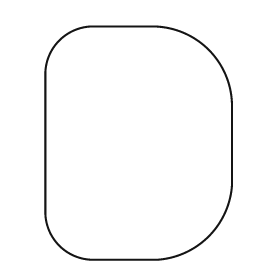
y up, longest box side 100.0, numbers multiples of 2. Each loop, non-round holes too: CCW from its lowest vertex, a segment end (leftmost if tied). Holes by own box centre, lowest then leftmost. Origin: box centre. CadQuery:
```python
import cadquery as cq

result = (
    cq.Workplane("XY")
    .moveTo(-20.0, -50.0)
    .lineTo(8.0, -50.0)
    .threePointArc((30.0, -40.0), (40.0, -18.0))
    .lineTo(40.0, 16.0)
    .threePointArc((30.0, 40.0), (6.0, 50.0))
    .lineTo(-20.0, 50.0)
    .threePointArc((-34.0, 44.0), (-40.0, 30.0))
    .lineTo(-40.0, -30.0)
    .threePointArc((-34.0, -44.0), (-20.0, -50.0))
    .close()
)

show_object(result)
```